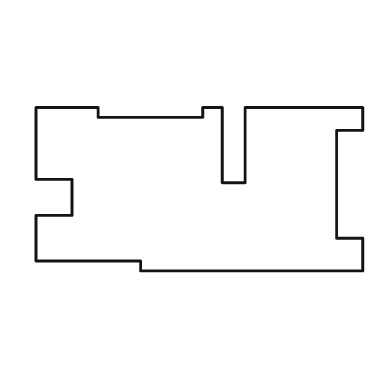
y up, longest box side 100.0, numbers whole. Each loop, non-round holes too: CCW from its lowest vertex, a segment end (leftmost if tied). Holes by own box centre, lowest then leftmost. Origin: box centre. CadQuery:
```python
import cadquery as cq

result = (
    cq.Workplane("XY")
    .moveTo(-18.0, -25.0)
    .lineTo(50.0, -25.0)
    .lineTo(50.0, -15.0)
    .lineTo(42.0, -15.0)
    .lineTo(42.0, 18.0)
    .lineTo(50.0, 18.0)
    .lineTo(50.0, 25.0)
    .lineTo(14.0, 25.0)
    .lineTo(14.0, 2.0)
    .lineTo(7.0, 2.0)
    .lineTo(7.0, 25.0)
    .lineTo(1.0, 25.0)
    .lineTo(1.0, 22.0)
    .lineTo(-31.0, 22.0)
    .lineTo(-31.0, 25.0)
    .lineTo(-50.0, 25.0)
    .lineTo(-50.0, 3.0)
    .lineTo(-39.0, 3.0)
    .lineTo(-39.0, -8.0)
    .lineTo(-50.0, -8.0)
    .lineTo(-50.0, -22.0)
    .lineTo(-18.0, -22.0)
    .close()
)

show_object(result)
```